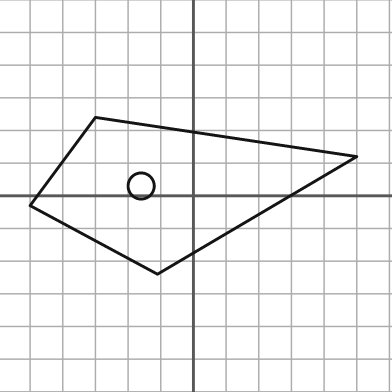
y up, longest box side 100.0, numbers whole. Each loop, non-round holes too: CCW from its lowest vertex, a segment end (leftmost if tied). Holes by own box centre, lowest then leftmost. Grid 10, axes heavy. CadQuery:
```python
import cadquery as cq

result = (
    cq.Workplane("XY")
    .moveTo(-11.0, -24.0)
    .lineTo(50.0, 12.0)
    .lineTo(-30.0, 24.0)
    .lineTo(-50.0, -3.0)
    .close()
    .moveTo(-16.0, 3.0)
    .circle(4.0)
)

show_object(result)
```